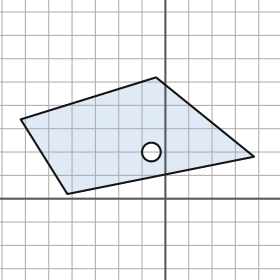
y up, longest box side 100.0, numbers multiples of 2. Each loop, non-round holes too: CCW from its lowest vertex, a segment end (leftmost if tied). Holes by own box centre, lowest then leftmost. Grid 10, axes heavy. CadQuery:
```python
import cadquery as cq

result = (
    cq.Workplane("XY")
    .moveTo(-42.0, 2.0)
    .lineTo(38.0, 18.0)
    .lineTo(-4.0, 52.0)
    .lineTo(-62.0, 34.0)
    .close()
    .moveTo(-6.0, 20.0)
    .circle(4.0)
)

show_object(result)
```